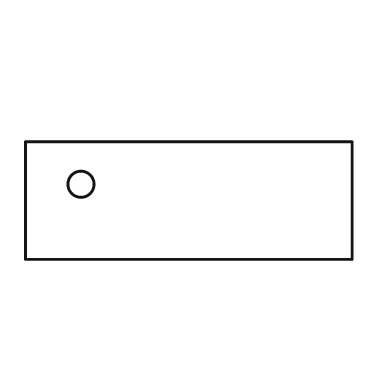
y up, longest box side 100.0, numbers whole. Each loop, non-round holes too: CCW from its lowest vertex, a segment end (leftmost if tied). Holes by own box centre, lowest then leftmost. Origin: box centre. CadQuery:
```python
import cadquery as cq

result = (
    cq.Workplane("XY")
    .moveTo(-50.0, -18.0)
    .lineTo(50.0, -18.0)
    .lineTo(50.0, 18.0)
    .lineTo(-50.0, 18.0)
    .close()
    .moveTo(-33.0, 5.0)
    .circle(4.0)
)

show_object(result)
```